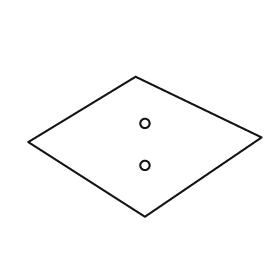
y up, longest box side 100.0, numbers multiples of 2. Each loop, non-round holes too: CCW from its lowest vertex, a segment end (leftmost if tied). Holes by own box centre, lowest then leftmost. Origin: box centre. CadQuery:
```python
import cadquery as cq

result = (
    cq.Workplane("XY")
    .moveTo(0.0, -30.0)
    .lineTo(50.0, 4.0)
    .lineTo(-4.0, 30.0)
    .lineTo(-50.0, 2.0)
    .close()
    .moveTo(0.0, -8.0)
    .circle(2.0)
    .moveTo(0.0, 10.0)
    .circle(2.0)
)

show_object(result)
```